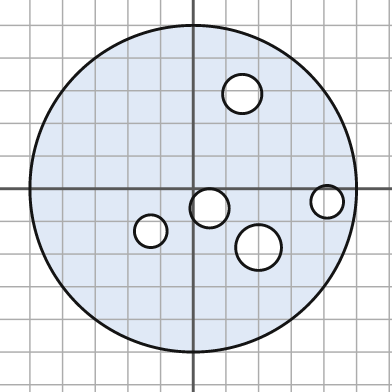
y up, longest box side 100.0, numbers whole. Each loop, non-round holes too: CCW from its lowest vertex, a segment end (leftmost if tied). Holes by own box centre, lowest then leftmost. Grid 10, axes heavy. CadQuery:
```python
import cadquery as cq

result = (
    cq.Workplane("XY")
    .moveTo(0.0, 0.0)
    .circle(50.0)
    .moveTo(20.0, -18.0)
    .circle(7.0)
    .moveTo(-13.0, -13.0)
    .circle(5.0)
    .moveTo(5.0, -6.0)
    .circle(6.0)
    .moveTo(41.0, -4.0)
    .circle(5.0)
    .moveTo(15.0, 29.0)
    .circle(6.0)
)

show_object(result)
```